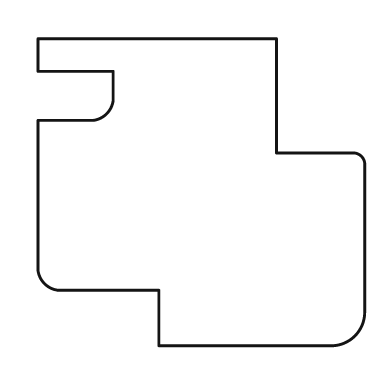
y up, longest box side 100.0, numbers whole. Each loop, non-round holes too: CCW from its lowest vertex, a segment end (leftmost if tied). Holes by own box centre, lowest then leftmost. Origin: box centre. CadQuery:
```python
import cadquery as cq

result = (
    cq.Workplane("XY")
    .moveTo(-13.0, -47.0)
    .lineTo(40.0, -47.0)
    .threePointArc((47.0, -44.0), (50.0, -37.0))
    .lineTo(50.0, 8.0)
    .threePointArc((49.0, 11.0), (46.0, 12.0))
    .lineTo(23.0, 12.0)
    .lineTo(23.0, 47.0)
    .lineTo(-50.0, 47.0)
    .lineTo(-50.0, 37.0)
    .lineTo(-27.0, 37.0)
    .lineTo(-27.0, 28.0)
    .threePointArc((-29.0, 24.0), (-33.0, 22.0))
    .lineTo(-50.0, 22.0)
    .lineTo(-50.0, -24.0)
    .threePointArc((-48.0, -28.0), (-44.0, -30.0))
    .lineTo(-13.0, -30.0)
    .close()
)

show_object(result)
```